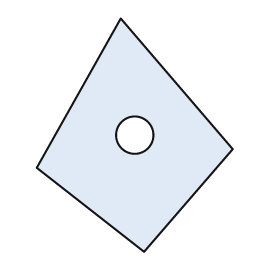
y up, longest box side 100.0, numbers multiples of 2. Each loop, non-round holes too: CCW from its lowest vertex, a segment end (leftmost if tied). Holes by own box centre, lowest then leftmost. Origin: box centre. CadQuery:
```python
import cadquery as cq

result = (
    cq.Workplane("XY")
    .moveTo(4.0, -50.0)
    .lineTo(42.0, -6.0)
    .lineTo(-6.0, 50.0)
    .lineTo(-42.0, -14.0)
    .close()
    .moveTo(0.0, 0.0)
    .circle(8.0)
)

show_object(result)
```